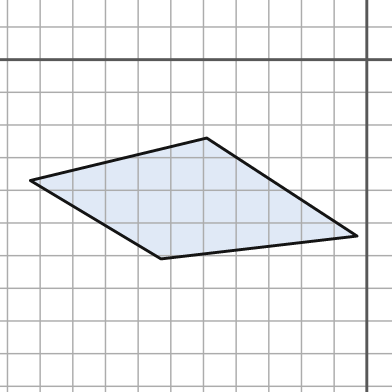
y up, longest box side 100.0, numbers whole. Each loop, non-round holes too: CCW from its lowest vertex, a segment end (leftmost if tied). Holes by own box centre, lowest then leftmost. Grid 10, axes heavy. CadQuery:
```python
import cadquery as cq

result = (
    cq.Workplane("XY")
    .moveTo(-63.0, -61.0)
    .lineTo(-3.0, -54.0)
    .lineTo(-49.0, -24.0)
    .lineTo(-103.0, -37.0)
    .close()
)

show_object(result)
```